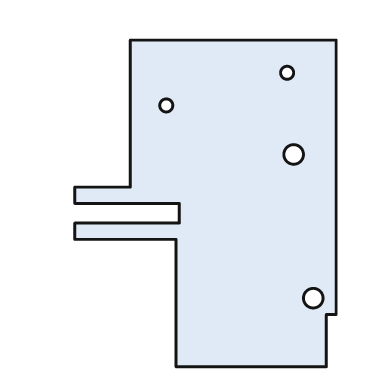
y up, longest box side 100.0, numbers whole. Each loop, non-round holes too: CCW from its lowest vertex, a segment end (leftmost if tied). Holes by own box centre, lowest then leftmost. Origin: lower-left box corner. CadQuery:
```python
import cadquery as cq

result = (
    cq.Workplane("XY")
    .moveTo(31.0, 0.0)
    .lineTo(77.0, 0.0)
    .lineTo(77.0, 16.0)
    .lineTo(80.0, 16.0)
    .lineTo(80.0, 100.0)
    .lineTo(17.0, 100.0)
    .lineTo(17.0, 55.0)
    .lineTo(0.0, 55.0)
    .lineTo(0.0, 50.0)
    .lineTo(32.0, 50.0)
    .lineTo(32.0, 44.0)
    .lineTo(0.0, 44.0)
    .lineTo(0.0, 39.0)
    .lineTo(31.0, 39.0)
    .close()
    .moveTo(73.0, 21.0)
    .circle(3.0)
    .moveTo(67.0, 65.0)
    .circle(3.0)
    .moveTo(28.0, 80.0)
    .circle(2.0)
    .moveTo(65.0, 90.0)
    .circle(2.0)
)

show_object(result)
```